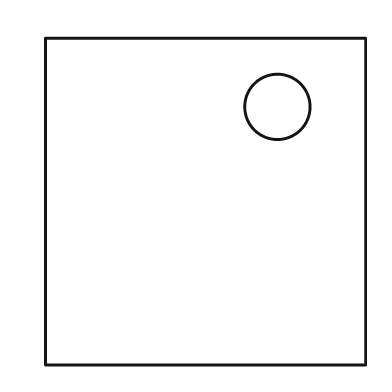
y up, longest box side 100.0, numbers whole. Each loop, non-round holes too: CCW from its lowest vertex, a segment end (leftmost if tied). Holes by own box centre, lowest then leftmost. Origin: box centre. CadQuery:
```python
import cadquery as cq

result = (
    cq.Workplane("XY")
    .moveTo(-49.0, -50.0)
    .lineTo(49.0, -50.0)
    .lineTo(49.0, 50.0)
    .lineTo(-49.0, 50.0)
    .close()
    .moveTo(22.0, 29.0)
    .circle(10.0)
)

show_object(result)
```